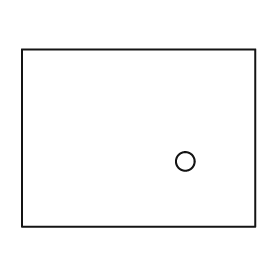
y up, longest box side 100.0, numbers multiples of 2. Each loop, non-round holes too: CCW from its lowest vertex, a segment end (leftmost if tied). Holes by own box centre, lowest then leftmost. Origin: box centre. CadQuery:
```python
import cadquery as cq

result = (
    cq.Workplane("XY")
    .moveTo(-50.0, -38.0)
    .lineTo(50.0, -38.0)
    .lineTo(50.0, 38.0)
    .lineTo(-50.0, 38.0)
    .close()
    .moveTo(20.0, -10.0)
    .circle(4.0)
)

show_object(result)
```